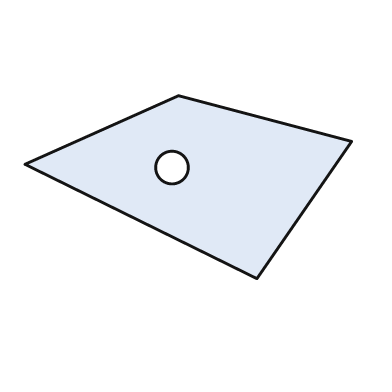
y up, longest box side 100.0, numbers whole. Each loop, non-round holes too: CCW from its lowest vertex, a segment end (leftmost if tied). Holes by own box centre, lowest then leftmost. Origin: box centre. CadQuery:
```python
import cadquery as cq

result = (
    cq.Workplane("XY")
    .moveTo(21.0, -28.0)
    .lineTo(50.0, 14.0)
    .lineTo(-3.0, 28.0)
    .lineTo(-50.0, 7.0)
    .close()
    .moveTo(-5.0, 6.0)
    .circle(5.0)
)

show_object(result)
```